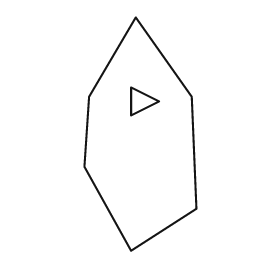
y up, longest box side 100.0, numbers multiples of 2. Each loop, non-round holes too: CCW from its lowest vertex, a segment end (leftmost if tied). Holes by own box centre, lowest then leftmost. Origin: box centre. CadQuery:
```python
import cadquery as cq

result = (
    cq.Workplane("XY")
    .moveTo(-4.0, -50.0)
    .lineTo(24.0, -32.0)
    .lineTo(22.0, 16.0)
    .lineTo(-2.0, 50.0)
    .lineTo(-22.0, 16.0)
    .lineTo(-24.0, -14.0)
    .close()
    .moveTo(-4.0, 8.0)
    .lineTo(8.0, 14.0)
    .lineTo(-4.0, 20.0)
    .close()
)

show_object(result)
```